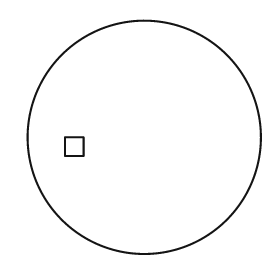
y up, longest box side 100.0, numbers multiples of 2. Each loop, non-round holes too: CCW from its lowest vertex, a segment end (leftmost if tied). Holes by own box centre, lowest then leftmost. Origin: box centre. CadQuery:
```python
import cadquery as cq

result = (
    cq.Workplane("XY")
    .moveTo(0.0, 0.0)
    .circle(50.0)
    .moveTo(-34.0, -8.0)
    .lineTo(-26.0, -8.0)
    .lineTo(-26.0, 0.0)
    .lineTo(-34.0, 0.0)
    .close()
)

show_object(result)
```